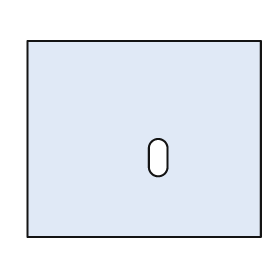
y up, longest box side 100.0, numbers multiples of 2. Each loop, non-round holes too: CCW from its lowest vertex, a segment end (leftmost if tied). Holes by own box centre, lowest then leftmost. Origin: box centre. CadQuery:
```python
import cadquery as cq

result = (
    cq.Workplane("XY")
    .moveTo(-50.0, -42.0)
    .lineTo(50.0, -42.0)
    .lineTo(50.0, 42.0)
    .lineTo(-50.0, 42.0)
    .close()
    .moveTo(2.0, -12.0)
    .threePointArc((6.0, -16.0), (10.0, -12.0))
    .lineTo(10.0, -4.0)
    .threePointArc((6.0, 0.0), (2.0, -4.0))
    .close()
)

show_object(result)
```